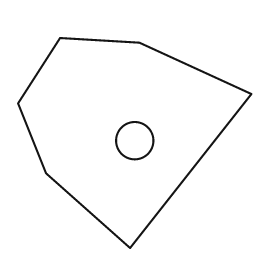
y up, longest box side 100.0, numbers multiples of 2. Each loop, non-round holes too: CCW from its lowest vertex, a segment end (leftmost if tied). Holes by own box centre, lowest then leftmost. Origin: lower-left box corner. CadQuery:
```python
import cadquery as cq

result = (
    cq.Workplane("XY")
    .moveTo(48.0, 0.0)
    .lineTo(100.0, 66.0)
    .lineTo(52.0, 88.0)
    .lineTo(18.0, 90.0)
    .lineTo(0.0, 62.0)
    .lineTo(12.0, 32.0)
    .close()
    .moveTo(50.0, 46.0)
    .circle(8.0)
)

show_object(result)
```